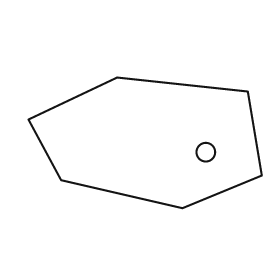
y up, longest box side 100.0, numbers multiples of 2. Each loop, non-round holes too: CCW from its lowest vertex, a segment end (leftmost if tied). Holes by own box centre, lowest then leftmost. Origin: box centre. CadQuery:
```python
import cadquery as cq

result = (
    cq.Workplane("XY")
    .moveTo(16.0, -28.0)
    .lineTo(50.0, -14.0)
    .lineTo(44.0, 22.0)
    .lineTo(-12.0, 28.0)
    .lineTo(-50.0, 10.0)
    .lineTo(-36.0, -16.0)
    .close()
    .moveTo(26.0, -4.0)
    .circle(4.0)
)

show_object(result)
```